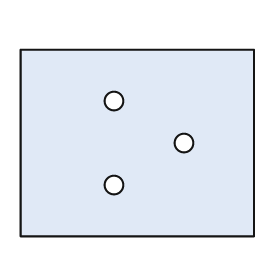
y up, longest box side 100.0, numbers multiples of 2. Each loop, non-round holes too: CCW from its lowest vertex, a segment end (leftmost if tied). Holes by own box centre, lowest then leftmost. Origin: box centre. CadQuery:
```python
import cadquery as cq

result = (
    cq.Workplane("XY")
    .moveTo(-50.0, -40.0)
    .lineTo(50.0, -40.0)
    .lineTo(50.0, 40.0)
    .lineTo(-50.0, 40.0)
    .close()
    .moveTo(-10.0, -18.0)
    .circle(4.0)
    .moveTo(20.0, 0.0)
    .circle(4.0)
    .moveTo(-10.0, 18.0)
    .circle(4.0)
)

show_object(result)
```